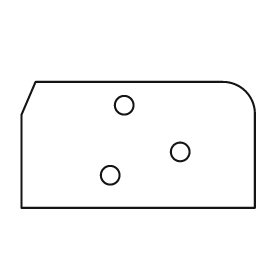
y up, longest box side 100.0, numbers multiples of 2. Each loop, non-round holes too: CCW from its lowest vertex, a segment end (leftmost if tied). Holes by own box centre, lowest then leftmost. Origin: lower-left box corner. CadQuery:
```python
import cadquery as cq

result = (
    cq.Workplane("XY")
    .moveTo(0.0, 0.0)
    .lineTo(100.0, 0.0)
    .lineTo(100.0, 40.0)
    .threePointArc((96.0, 50.0), (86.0, 54.0))
    .lineTo(6.0, 54.0)
    .lineTo(0.0, 40.0)
    .close()
    .moveTo(38.0, 14.0)
    .circle(4.0)
    .moveTo(68.0, 24.0)
    .circle(4.0)
    .moveTo(44.0, 44.0)
    .circle(4.0)
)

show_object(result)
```